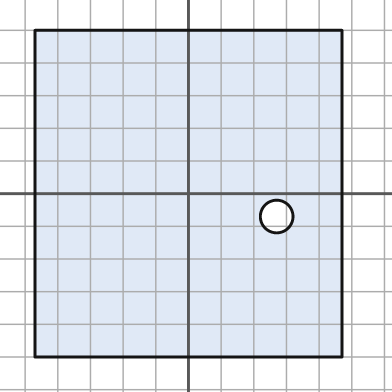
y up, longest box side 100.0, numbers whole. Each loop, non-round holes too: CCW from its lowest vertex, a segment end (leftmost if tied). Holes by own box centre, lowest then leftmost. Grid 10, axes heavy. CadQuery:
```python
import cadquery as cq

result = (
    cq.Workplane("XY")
    .moveTo(-47.0, -50.0)
    .lineTo(47.0, -50.0)
    .lineTo(47.0, 50.0)
    .lineTo(-47.0, 50.0)
    .close()
    .moveTo(27.0, -7.0)
    .circle(5.0)
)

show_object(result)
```